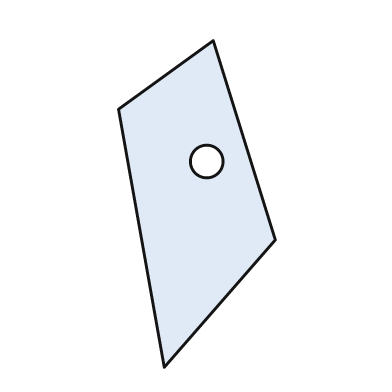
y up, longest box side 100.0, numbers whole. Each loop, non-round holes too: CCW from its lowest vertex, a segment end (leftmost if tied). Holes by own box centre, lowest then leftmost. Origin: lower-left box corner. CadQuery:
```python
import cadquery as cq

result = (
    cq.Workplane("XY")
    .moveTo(14.0, 0.0)
    .lineTo(48.0, 39.0)
    .lineTo(29.0, 100.0)
    .lineTo(0.0, 79.0)
    .close()
    .moveTo(27.0, 63.0)
    .circle(5.0)
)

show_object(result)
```